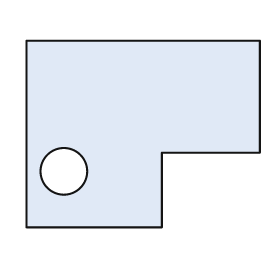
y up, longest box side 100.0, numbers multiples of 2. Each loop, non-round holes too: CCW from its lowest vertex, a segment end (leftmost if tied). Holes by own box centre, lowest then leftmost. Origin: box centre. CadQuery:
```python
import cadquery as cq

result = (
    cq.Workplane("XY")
    .moveTo(-50.0, -40.0)
    .lineTo(8.0, -40.0)
    .lineTo(8.0, -8.0)
    .lineTo(50.0, -8.0)
    .lineTo(50.0, 40.0)
    .lineTo(-50.0, 40.0)
    .close()
    .moveTo(-34.0, -16.0)
    .circle(10.0)
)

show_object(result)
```